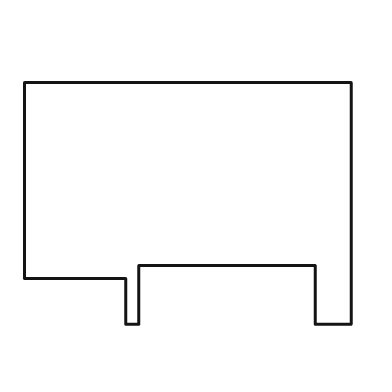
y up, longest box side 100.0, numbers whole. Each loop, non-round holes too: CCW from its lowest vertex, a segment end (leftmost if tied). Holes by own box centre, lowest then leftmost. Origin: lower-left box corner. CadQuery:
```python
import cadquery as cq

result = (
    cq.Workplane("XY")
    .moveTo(31.0, 0.0)
    .lineTo(35.0, 0.0)
    .lineTo(35.0, 18.0)
    .lineTo(89.0, 18.0)
    .lineTo(89.0, 0.0)
    .lineTo(100.0, 0.0)
    .lineTo(100.0, 74.0)
    .lineTo(0.0, 74.0)
    .lineTo(0.0, 14.0)
    .lineTo(31.0, 14.0)
    .close()
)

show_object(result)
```